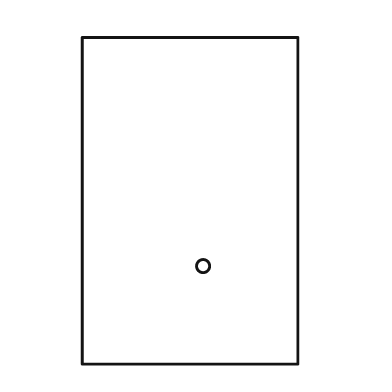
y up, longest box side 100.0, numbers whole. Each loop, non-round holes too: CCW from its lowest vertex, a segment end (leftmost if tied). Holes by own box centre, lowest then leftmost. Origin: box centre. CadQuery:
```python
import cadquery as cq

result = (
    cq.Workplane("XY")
    .moveTo(-33.0, -50.0)
    .lineTo(33.0, -50.0)
    .lineTo(33.0, 50.0)
    .lineTo(-33.0, 50.0)
    .close()
    .moveTo(4.0, -20.0)
    .circle(2.0)
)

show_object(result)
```